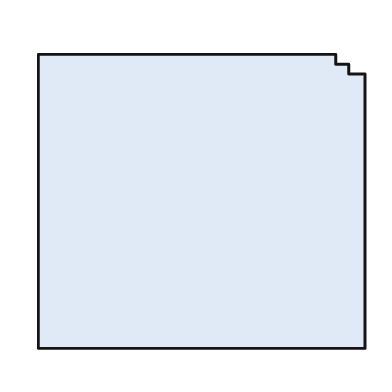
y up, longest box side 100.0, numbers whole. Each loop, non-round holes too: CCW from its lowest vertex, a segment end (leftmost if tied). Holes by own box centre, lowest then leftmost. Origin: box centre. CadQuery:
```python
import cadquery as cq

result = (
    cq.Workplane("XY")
    .moveTo(-50.0, -45.0)
    .lineTo(50.0, -45.0)
    .lineTo(50.0, 39.0)
    .lineTo(45.0, 39.0)
    .lineTo(45.0, 42.0)
    .lineTo(41.0, 42.0)
    .lineTo(41.0, 45.0)
    .lineTo(-50.0, 45.0)
    .close()
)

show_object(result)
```